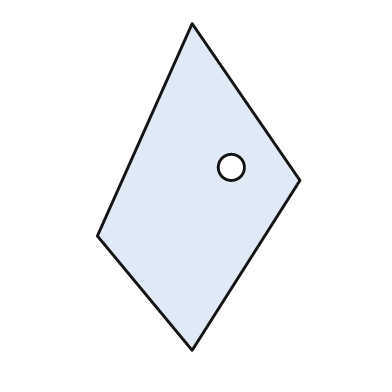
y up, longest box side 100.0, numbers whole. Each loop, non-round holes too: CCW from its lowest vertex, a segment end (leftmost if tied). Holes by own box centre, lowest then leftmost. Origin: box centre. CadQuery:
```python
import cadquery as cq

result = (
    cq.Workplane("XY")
    .moveTo(-2.0, -50.0)
    .lineTo(31.0, 2.0)
    .lineTo(-2.0, 50.0)
    .lineTo(-31.0, -15.0)
    .close()
    .moveTo(10.0, 6.0)
    .circle(4.0)
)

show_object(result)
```